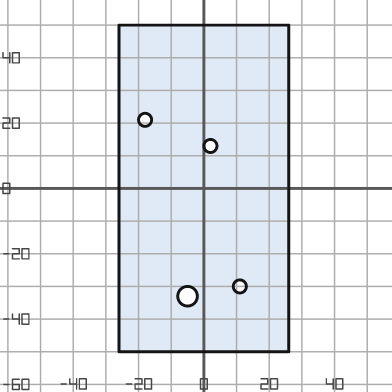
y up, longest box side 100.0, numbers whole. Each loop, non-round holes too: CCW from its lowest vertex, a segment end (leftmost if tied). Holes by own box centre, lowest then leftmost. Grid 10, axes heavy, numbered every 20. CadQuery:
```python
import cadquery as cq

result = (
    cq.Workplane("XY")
    .moveTo(-26.0, -50.0)
    .lineTo(26.0, -50.0)
    .lineTo(26.0, 50.0)
    .lineTo(-26.0, 50.0)
    .close()
    .moveTo(-5.0, -33.0)
    .circle(3.0)
    .moveTo(11.0, -30.0)
    .circle(2.0)
    .moveTo(2.0, 13.0)
    .circle(2.0)
    .moveTo(-18.0, 21.0)
    .circle(2.0)
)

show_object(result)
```